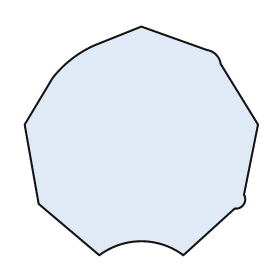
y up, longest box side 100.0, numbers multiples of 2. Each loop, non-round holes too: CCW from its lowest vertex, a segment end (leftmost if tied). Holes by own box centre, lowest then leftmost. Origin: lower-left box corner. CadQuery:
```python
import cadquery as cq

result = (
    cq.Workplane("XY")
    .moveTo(32.0, 0.0)
    .threePointArc((50.0, 6.0), (68.0, 0.0))
    .lineTo(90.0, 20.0)
    .threePointArc((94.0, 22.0), (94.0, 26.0))
    .lineTo(100.0, 56.0)
    .lineTo(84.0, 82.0)
    .threePointArc((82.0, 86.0), (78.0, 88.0))
    .lineTo(50.0, 98.0)
    .lineTo(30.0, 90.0)
    .threePointArc((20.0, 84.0), (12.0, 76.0))
    .lineTo(0.0, 56.0)
    .lineTo(6.0, 22.0)
    .close()
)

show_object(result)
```